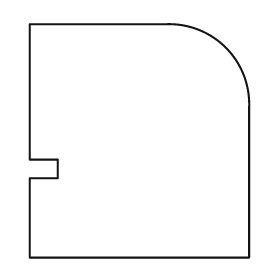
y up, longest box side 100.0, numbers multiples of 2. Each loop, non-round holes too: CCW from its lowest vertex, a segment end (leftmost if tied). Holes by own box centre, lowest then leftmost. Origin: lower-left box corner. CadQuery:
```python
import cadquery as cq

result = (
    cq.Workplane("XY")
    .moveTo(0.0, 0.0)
    .lineTo(94.0, 0.0)
    .lineTo(94.0, 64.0)
    .threePointArc((84.0, 90.0), (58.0, 100.0))
    .lineTo(0.0, 100.0)
    .lineTo(0.0, 42.0)
    .lineTo(12.0, 42.0)
    .lineTo(12.0, 34.0)
    .lineTo(0.0, 34.0)
    .close()
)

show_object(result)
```